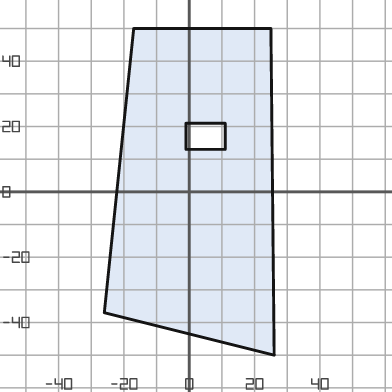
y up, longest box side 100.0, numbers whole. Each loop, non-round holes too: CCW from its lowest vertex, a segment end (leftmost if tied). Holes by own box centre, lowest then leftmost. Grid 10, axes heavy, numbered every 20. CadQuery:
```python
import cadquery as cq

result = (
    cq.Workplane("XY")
    .moveTo(26.0, -50.0)
    .lineTo(25.0, 50.0)
    .lineTo(-17.0, 50.0)
    .lineTo(-26.0, -37.0)
    .close()
    .moveTo(-1.0, 13.0)
    .lineTo(11.0, 13.0)
    .lineTo(11.0, 21.0)
    .lineTo(-1.0, 21.0)
    .close()
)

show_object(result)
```